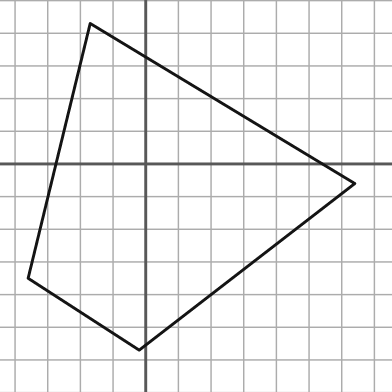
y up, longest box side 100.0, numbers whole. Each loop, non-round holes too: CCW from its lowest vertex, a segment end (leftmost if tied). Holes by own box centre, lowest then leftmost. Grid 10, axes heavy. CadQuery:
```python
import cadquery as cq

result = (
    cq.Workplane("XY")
    .moveTo(-2.0, -57.0)
    .lineTo(64.0, -6.0)
    .lineTo(-17.0, 43.0)
    .lineTo(-36.0, -35.0)
    .close()
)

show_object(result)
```